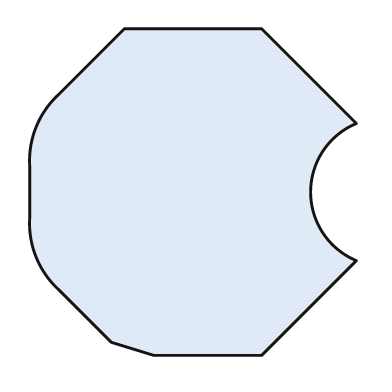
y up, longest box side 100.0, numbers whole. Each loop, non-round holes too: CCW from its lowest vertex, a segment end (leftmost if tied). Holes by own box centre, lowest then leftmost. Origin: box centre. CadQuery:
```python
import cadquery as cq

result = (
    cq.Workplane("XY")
    .moveTo(-12.0, -50.0)
    .lineTo(21.0, -50.0)
    .lineTo(50.0, -21.0)
    .threePointArc((36.0, 0.0), (50.0, 21.0))
    .lineTo(21.0, 50.0)
    .lineTo(-21.0, 50.0)
    .lineTo(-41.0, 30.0)
    .threePointArc((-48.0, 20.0), (-50.0, 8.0))
    .lineTo(-50.0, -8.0)
    .threePointArc((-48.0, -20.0), (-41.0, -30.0))
    .lineTo(-25.0, -46.0)
    .close()
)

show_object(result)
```